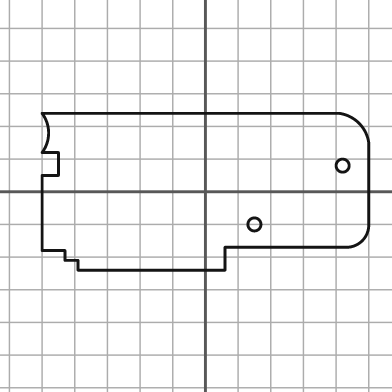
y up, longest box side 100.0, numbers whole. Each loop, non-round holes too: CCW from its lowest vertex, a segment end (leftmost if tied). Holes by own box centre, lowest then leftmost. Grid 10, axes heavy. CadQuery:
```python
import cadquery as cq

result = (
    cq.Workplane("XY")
    .moveTo(-39.0, -24.0)
    .lineTo(6.0, -24.0)
    .lineTo(6.0, -17.0)
    .lineTo(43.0, -17.0)
    .threePointArc((48.0, -15.0), (50.0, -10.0))
    .lineTo(50.0, 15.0)
    .threePointArc((47.0, 21.0), (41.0, 24.0))
    .lineTo(-50.0, 24.0)
    .threePointArc((-48.0, 18.0), (-50.0, 12.0))
    .lineTo(-45.0, 12.0)
    .lineTo(-45.0, 5.0)
    .lineTo(-50.0, 5.0)
    .lineTo(-50.0, -18.0)
    .lineTo(-43.0, -18.0)
    .lineTo(-43.0, -21.0)
    .lineTo(-39.0, -21.0)
    .close()
    .moveTo(15.0, -10.0)
    .circle(2.0)
    .moveTo(42.0, 8.0)
    .circle(2.0)
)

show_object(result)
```